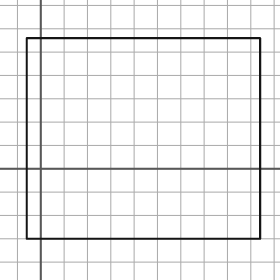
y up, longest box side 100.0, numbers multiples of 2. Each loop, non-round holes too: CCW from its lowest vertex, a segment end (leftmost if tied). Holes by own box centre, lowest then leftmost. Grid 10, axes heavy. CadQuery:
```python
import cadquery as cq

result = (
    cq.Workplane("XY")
    .moveTo(-6.0, -30.0)
    .lineTo(94.0, -30.0)
    .lineTo(94.0, 56.0)
    .lineTo(-6.0, 56.0)
    .close()
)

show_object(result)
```